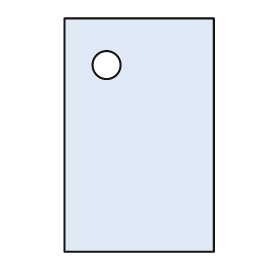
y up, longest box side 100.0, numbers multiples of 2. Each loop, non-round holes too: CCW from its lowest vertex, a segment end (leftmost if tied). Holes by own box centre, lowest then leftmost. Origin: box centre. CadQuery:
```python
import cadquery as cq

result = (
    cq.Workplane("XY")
    .moveTo(-32.0, -50.0)
    .lineTo(32.0, -50.0)
    .lineTo(32.0, 50.0)
    .lineTo(-32.0, 50.0)
    .close()
    .moveTo(-14.0, 30.0)
    .circle(6.0)
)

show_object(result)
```